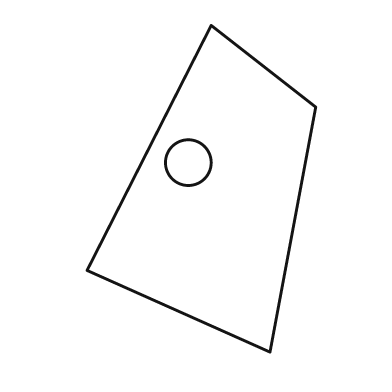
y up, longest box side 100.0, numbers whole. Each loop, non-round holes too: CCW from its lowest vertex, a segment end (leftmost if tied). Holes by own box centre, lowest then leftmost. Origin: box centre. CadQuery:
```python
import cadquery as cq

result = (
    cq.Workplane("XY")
    .moveTo(21.0, -50.0)
    .lineTo(35.0, 25.0)
    .lineTo(3.0, 50.0)
    .lineTo(-35.0, -25.0)
    .close()
    .moveTo(-4.0, 8.0)
    .circle(7.0)
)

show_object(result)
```